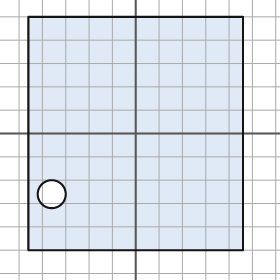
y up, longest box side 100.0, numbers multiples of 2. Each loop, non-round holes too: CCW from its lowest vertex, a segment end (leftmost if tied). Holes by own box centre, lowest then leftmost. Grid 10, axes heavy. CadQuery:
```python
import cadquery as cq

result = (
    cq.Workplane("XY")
    .moveTo(-46.0, -50.0)
    .lineTo(46.0, -50.0)
    .lineTo(46.0, 50.0)
    .lineTo(-46.0, 50.0)
    .close()
    .moveTo(-36.0, -26.0)
    .circle(6.0)
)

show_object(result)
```